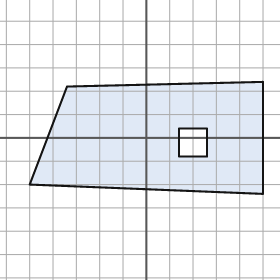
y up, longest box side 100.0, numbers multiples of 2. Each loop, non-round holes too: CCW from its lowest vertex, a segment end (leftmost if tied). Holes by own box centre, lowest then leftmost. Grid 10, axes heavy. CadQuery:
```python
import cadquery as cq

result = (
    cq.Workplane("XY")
    .moveTo(50.0, -24.0)
    .lineTo(50.0, 24.0)
    .lineTo(-34.0, 22.0)
    .lineTo(-50.0, -20.0)
    .close()
    .moveTo(14.0, -8.0)
    .lineTo(26.0, -8.0)
    .lineTo(26.0, 4.0)
    .lineTo(14.0, 4.0)
    .close()
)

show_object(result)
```